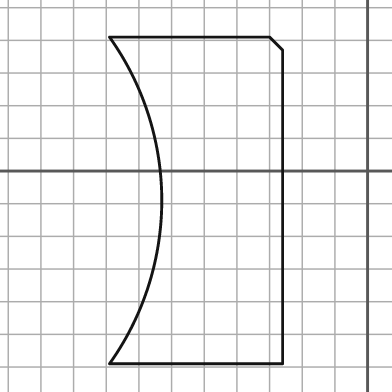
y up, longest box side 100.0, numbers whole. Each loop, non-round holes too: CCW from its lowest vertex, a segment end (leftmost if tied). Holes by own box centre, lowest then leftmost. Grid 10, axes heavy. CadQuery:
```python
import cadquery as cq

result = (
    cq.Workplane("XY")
    .moveTo(-79.0, -59.0)
    .lineTo(-26.0, -59.0)
    .lineTo(-26.0, 37.0)
    .lineTo(-30.0, 41.0)
    .lineTo(-79.0, 41.0)
    .threePointArc((-63.0, -9.0), (-79.0, -59.0))
    .close()
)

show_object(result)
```